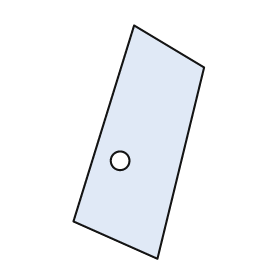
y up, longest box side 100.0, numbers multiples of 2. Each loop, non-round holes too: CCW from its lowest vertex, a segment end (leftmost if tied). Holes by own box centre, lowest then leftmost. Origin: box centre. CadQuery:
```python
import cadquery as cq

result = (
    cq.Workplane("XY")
    .moveTo(8.0, -50.0)
    .lineTo(28.0, 32.0)
    .lineTo(-2.0, 50.0)
    .lineTo(-28.0, -34.0)
    .close()
    .moveTo(-8.0, -8.0)
    .circle(4.0)
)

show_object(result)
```